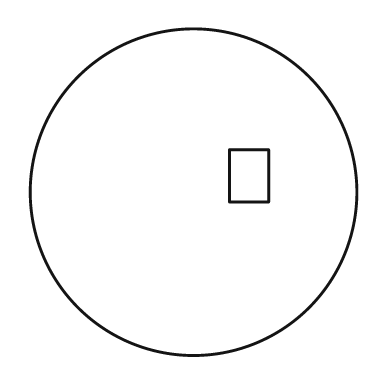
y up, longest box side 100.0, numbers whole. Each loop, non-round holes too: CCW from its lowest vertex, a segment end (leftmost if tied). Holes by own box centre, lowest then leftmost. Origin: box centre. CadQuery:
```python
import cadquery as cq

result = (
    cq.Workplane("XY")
    .moveTo(0.0, 0.0)
    .circle(50.0)
    .moveTo(11.0, -3.0)
    .lineTo(23.0, -3.0)
    .lineTo(23.0, 13.0)
    .lineTo(11.0, 13.0)
    .close()
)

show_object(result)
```